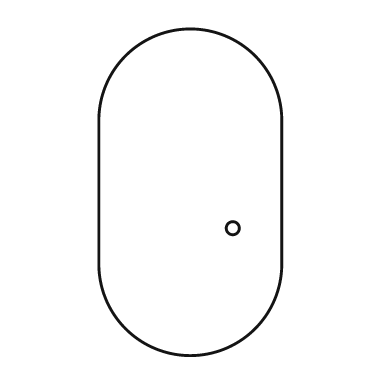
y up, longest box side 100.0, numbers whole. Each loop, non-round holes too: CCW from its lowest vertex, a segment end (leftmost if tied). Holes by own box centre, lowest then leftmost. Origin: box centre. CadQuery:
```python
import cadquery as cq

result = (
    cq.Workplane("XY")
    .moveTo(-28.0, -22.0)
    .threePointArc((0.0, -50.0), (28.0, -22.0))
    .lineTo(28.0, 22.0)
    .threePointArc((0.0, 50.0), (-28.0, 22.0))
    .close()
    .moveTo(13.0, -11.0)
    .circle(2.0)
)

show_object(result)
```